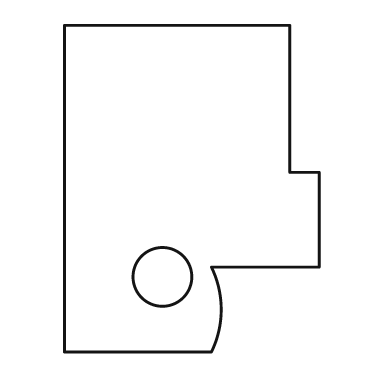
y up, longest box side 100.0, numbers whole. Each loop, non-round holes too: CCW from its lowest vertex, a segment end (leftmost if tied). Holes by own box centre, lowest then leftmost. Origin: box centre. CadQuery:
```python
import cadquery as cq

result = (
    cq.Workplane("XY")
    .moveTo(-39.0, -50.0)
    .lineTo(6.0, -50.0)
    .threePointArc((9.0, -37.0), (6.0, -24.0))
    .lineTo(39.0, -24.0)
    .lineTo(39.0, 5.0)
    .lineTo(30.0, 5.0)
    .lineTo(30.0, 50.0)
    .lineTo(-39.0, 50.0)
    .close()
    .moveTo(-9.0, -27.0)
    .circle(9.0)
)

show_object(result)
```